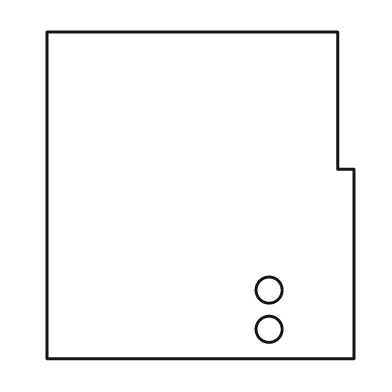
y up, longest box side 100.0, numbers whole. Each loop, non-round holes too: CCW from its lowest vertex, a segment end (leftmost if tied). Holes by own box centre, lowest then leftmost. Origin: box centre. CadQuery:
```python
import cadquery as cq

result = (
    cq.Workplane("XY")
    .moveTo(-47.0, -50.0)
    .lineTo(47.0, -50.0)
    .lineTo(47.0, 8.0)
    .lineTo(42.0, 8.0)
    .lineTo(42.0, 50.0)
    .lineTo(-47.0, 50.0)
    .close()
    .moveTo(21.0, -41.0)
    .circle(4.0)
    .moveTo(21.0, -29.0)
    .circle(4.0)
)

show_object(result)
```